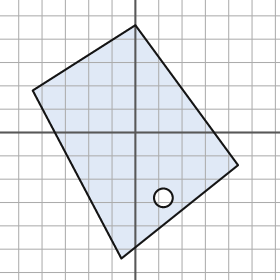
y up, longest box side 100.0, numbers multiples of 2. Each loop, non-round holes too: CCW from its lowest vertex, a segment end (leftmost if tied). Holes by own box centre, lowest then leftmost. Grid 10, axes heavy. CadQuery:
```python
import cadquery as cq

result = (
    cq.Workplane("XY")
    .moveTo(-6.0, -54.0)
    .lineTo(44.0, -14.0)
    .lineTo(0.0, 46.0)
    .lineTo(-44.0, 18.0)
    .close()
    .moveTo(12.0, -28.0)
    .circle(4.0)
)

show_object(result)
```